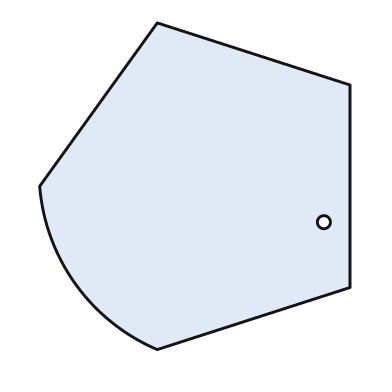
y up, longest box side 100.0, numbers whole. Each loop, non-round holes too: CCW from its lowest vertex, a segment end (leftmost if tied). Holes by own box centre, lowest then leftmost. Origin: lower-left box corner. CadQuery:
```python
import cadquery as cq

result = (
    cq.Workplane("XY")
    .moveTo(36.0, 0.0)
    .lineTo(95.0, 19.0)
    .lineTo(95.0, 81.0)
    .lineTo(36.0, 100.0)
    .lineTo(0.0, 50.0)
    .threePointArc((11.0, 20.0), (36.0, 0.0))
    .close()
    .moveTo(87.0, 39.0)
    .circle(2.0)
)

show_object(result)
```